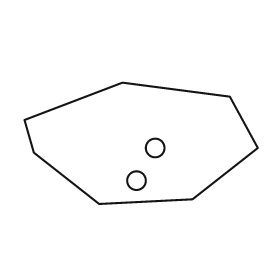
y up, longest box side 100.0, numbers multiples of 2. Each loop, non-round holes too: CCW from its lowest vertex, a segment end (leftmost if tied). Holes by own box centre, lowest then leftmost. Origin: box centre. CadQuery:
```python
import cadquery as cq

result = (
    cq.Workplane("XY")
    .moveTo(-18.0, -26.0)
    .lineTo(22.0, -24.0)
    .lineTo(50.0, -2.0)
    .lineTo(38.0, 20.0)
    .lineTo(-8.0, 26.0)
    .lineTo(-50.0, 10.0)
    .lineTo(-46.0, -4.0)
    .close()
    .moveTo(-2.0, -16.0)
    .circle(4.0)
    .moveTo(6.0, -2.0)
    .circle(4.0)
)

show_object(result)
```